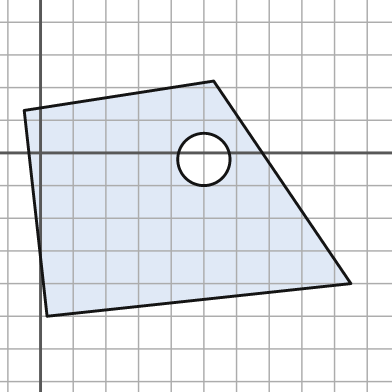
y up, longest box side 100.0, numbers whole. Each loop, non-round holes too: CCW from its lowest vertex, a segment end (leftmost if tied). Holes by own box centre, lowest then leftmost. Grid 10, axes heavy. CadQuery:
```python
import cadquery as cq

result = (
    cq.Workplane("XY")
    .moveTo(2.0, -50.0)
    .lineTo(95.0, -40.0)
    .lineTo(53.0, 22.0)
    .lineTo(-5.0, 13.0)
    .close()
    .moveTo(50.0, -2.0)
    .circle(8.0)
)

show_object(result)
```